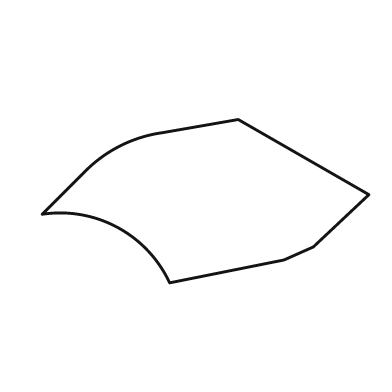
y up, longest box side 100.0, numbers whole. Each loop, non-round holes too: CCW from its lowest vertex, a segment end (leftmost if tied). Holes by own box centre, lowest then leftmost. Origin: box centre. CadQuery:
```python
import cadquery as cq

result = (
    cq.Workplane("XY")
    .moveTo(-11.0, -25.0)
    .lineTo(24.0, -18.0)
    .lineTo(33.0, -14.0)
    .lineTo(50.0, 2.0)
    .lineTo(10.0, 25.0)
    .lineTo(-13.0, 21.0)
    .threePointArc((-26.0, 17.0), (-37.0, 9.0))
    .lineTo(-50.0, -4.0)
    .threePointArc((-27.0, -8.0), (-11.0, -25.0))
    .close()
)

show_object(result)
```